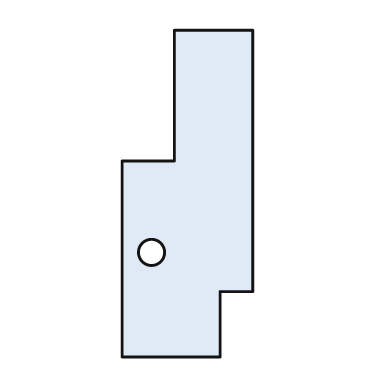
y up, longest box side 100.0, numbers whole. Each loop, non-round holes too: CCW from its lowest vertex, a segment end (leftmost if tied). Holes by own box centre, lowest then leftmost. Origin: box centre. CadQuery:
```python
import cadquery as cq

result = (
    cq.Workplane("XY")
    .moveTo(-20.0, -50.0)
    .lineTo(10.0, -50.0)
    .lineTo(10.0, -30.0)
    .lineTo(20.0, -30.0)
    .lineTo(20.0, 50.0)
    .lineTo(-4.0, 50.0)
    .lineTo(-4.0, 10.0)
    .lineTo(-20.0, 10.0)
    .close()
    .moveTo(-11.0, -18.0)
    .circle(4.0)
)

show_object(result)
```